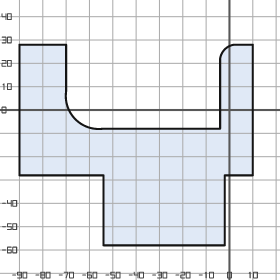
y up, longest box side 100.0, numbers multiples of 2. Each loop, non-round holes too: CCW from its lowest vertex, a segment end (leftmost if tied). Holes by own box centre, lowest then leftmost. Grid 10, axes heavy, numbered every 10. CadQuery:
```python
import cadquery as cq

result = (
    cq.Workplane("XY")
    .moveTo(-54.0, -58.0)
    .lineTo(-2.0, -58.0)
    .lineTo(-2.0, -28.0)
    .lineTo(10.0, -28.0)
    .lineTo(10.0, 28.0)
    .lineTo(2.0, 28.0)
    .threePointArc((-2.0, 26.0), (-4.0, 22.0))
    .lineTo(-4.0, -8.0)
    .lineTo(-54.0, -8.0)
    .threePointArc((-66.0, -4.0), (-70.0, 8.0))
    .lineTo(-70.0, 28.0)
    .lineTo(-90.0, 28.0)
    .lineTo(-90.0, -28.0)
    .lineTo(-54.0, -28.0)
    .close()
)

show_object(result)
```